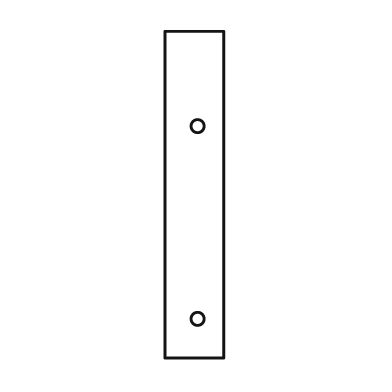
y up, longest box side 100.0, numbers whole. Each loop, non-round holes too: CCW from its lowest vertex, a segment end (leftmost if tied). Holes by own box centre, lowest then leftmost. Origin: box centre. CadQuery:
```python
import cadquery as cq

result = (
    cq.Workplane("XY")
    .moveTo(-9.0, -50.0)
    .lineTo(9.0, -50.0)
    .lineTo(9.0, 50.0)
    .lineTo(-9.0, 50.0)
    .close()
    .moveTo(1.0, -38.0)
    .circle(2.0)
    .moveTo(1.0, 21.0)
    .circle(2.0)
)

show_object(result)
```